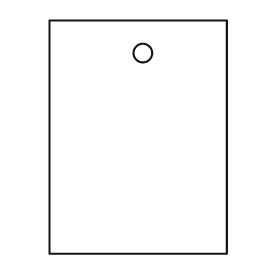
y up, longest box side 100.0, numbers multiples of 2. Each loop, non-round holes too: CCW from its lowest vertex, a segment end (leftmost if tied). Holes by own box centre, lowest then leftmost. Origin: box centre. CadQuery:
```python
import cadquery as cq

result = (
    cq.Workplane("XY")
    .moveTo(-38.0, -50.0)
    .lineTo(38.0, -50.0)
    .lineTo(38.0, 50.0)
    .lineTo(-38.0, 50.0)
    .close()
    .moveTo(2.0, 36.0)
    .circle(4.0)
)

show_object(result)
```